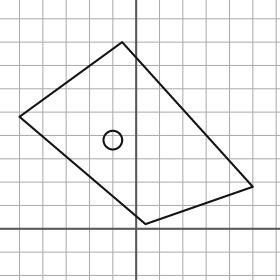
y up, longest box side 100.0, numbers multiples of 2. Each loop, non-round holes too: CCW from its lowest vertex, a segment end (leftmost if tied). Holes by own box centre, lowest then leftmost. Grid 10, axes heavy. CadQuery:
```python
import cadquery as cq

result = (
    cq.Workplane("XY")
    .moveTo(4.0, 2.0)
    .lineTo(50.0, 18.0)
    .lineTo(-6.0, 80.0)
    .lineTo(-50.0, 48.0)
    .close()
    .moveTo(-10.0, 38.0)
    .circle(4.0)
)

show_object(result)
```